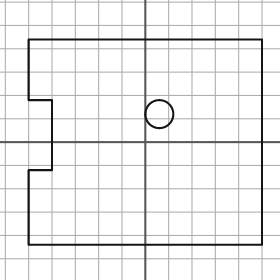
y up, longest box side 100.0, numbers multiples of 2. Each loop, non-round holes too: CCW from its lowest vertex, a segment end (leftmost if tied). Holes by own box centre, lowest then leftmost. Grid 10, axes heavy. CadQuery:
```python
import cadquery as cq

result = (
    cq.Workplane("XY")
    .moveTo(-50.0, -44.0)
    .lineTo(50.0, -44.0)
    .lineTo(50.0, 44.0)
    .lineTo(-50.0, 44.0)
    .lineTo(-50.0, 18.0)
    .lineTo(-40.0, 18.0)
    .lineTo(-40.0, -12.0)
    .lineTo(-50.0, -12.0)
    .close()
    .moveTo(6.0, 12.0)
    .circle(6.0)
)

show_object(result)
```